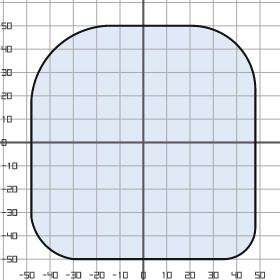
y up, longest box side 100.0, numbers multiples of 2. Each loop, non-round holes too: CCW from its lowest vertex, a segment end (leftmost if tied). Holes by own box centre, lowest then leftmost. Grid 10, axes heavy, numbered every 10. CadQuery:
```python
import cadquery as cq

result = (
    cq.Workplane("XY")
    .moveTo(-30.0, -50.0)
    .lineTo(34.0, -50.0)
    .threePointArc((44.0, -46.0), (48.0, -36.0))
    .lineTo(48.0, 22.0)
    .threePointArc((40.0, 42.0), (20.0, 50.0))
    .lineTo(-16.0, 50.0)
    .threePointArc((-38.0, 40.0), (-48.0, 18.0))
    .lineTo(-48.0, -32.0)
    .threePointArc((-42.0, -44.0), (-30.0, -50.0))
    .close()
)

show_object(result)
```